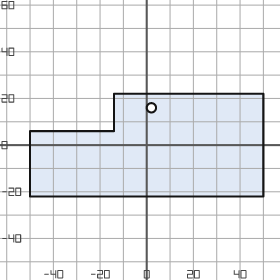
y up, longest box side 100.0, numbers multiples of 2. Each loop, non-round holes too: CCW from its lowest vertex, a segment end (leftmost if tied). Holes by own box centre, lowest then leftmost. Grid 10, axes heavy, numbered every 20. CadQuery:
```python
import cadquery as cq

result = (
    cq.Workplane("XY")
    .moveTo(-50.0, -22.0)
    .lineTo(50.0, -22.0)
    .lineTo(50.0, 22.0)
    .lineTo(-14.0, 22.0)
    .lineTo(-14.0, 6.0)
    .lineTo(-50.0, 6.0)
    .close()
    .moveTo(2.0, 16.0)
    .circle(2.0)
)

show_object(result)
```